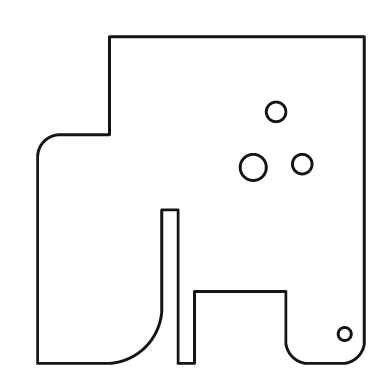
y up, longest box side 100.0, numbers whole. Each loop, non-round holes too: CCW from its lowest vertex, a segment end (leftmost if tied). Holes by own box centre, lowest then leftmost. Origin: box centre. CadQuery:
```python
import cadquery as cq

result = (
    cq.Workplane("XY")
    .moveTo(-50.0, -50.0)
    .lineTo(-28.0, -50.0)
    .threePointArc((-17.0, -45.0), (-12.0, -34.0))
    .lineTo(-12.0, -3.0)
    .lineTo(-7.0, -3.0)
    .lineTo(-7.0, -50.0)
    .lineTo(-2.0, -50.0)
    .lineTo(-2.0, -28.0)
    .lineTo(26.0, -28.0)
    .lineTo(26.0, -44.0)
    .threePointArc((28.0, -48.0), (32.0, -50.0))
    .lineTo(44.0, -50.0)
    .threePointArc((48.0, -48.0), (50.0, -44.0))
    .lineTo(50.0, 50.0)
    .lineTo(-28.0, 50.0)
    .lineTo(-28.0, 20.0)
    .lineTo(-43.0, 20.0)
    .threePointArc((-48.0, 18.0), (-50.0, 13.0))
    .close()
    .moveTo(44.0, -41.0)
    .circle(2.0)
    .moveTo(16.0, 10.0)
    .circle(4.0)
    .moveTo(31.0, 11.0)
    .circle(3.0)
    .moveTo(23.0, 27.0)
    .circle(3.0)
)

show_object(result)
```